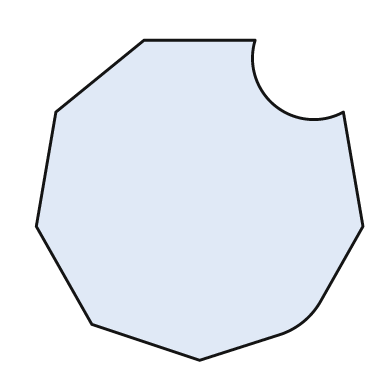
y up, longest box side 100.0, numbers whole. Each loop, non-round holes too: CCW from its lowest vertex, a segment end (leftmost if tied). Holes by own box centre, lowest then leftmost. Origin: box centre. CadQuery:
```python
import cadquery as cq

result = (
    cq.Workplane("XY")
    .moveTo(0.0, -49.0)
    .lineTo(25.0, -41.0)
    .threePointArc((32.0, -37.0), (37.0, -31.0))
    .lineTo(50.0, -8.0)
    .lineTo(44.0, 27.0)
    .threePointArc((23.0, 29.0), (17.0, 49.0))
    .lineTo(-17.0, 49.0)
    .lineTo(-44.0, 27.0)
    .lineTo(-50.0, -8.0)
    .lineTo(-33.0, -38.0)
    .close()
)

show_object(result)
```